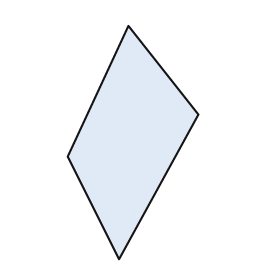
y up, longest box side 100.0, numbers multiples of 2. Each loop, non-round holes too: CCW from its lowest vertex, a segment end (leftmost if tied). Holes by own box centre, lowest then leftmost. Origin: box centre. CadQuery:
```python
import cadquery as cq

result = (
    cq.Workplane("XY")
    .moveTo(-6.0, -50.0)
    .lineTo(28.0, 12.0)
    .lineTo(-2.0, 50.0)
    .lineTo(-28.0, -6.0)
    .close()
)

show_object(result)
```